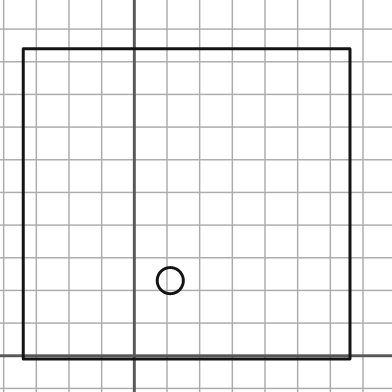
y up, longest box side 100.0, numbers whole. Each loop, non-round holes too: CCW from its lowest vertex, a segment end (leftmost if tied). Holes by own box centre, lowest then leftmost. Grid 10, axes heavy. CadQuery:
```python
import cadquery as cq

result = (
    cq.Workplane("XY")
    .moveTo(-34.0, -1.0)
    .lineTo(66.0, -1.0)
    .lineTo(66.0, 94.0)
    .lineTo(-34.0, 94.0)
    .close()
    .moveTo(11.0, 23.0)
    .circle(4.0)
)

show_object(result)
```